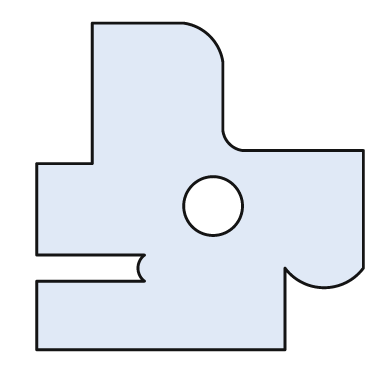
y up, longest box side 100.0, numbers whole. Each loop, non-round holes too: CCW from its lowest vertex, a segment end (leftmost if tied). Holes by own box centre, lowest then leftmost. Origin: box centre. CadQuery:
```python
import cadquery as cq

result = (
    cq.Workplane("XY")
    .moveTo(-50.0, -50.0)
    .lineTo(26.0, -50.0)
    .lineTo(26.0, -25.0)
    .threePointArc((38.0, -31.0), (50.0, -25.0))
    .lineTo(50.0, 11.0)
    .lineTo(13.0, 11.0)
    .threePointArc((9.0, 13.0), (7.0, 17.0))
    .lineTo(7.0, 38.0)
    .threePointArc((3.0, 46.0), (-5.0, 50.0))
    .lineTo(-33.0, 50.0)
    .lineTo(-33.0, 7.0)
    .lineTo(-50.0, 7.0)
    .lineTo(-50.0, -21.0)
    .lineTo(-17.0, -21.0)
    .threePointArc((-19.0, -25.0), (-17.0, -29.0))
    .lineTo(-50.0, -29.0)
    .close()
    .moveTo(4.0, -6.0)
    .circle(9.0)
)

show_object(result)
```